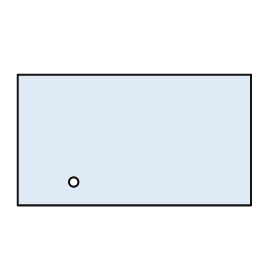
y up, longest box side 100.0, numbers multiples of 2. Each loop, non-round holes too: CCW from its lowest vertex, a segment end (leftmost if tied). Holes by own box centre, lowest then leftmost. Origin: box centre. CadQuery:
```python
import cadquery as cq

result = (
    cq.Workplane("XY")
    .moveTo(-50.0, -28.0)
    .lineTo(50.0, -28.0)
    .lineTo(50.0, 28.0)
    .lineTo(-50.0, 28.0)
    .close()
    .moveTo(-26.0, -18.0)
    .circle(2.0)
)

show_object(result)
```